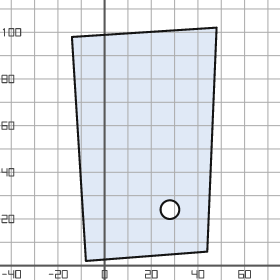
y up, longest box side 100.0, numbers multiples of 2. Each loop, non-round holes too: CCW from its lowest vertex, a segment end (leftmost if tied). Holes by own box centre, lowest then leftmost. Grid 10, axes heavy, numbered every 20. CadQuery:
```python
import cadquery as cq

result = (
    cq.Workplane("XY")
    .moveTo(-8.0, 2.0)
    .lineTo(44.0, 6.0)
    .lineTo(48.0, 102.0)
    .lineTo(-14.0, 98.0)
    .close()
    .moveTo(28.0, 24.0)
    .circle(4.0)
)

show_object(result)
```